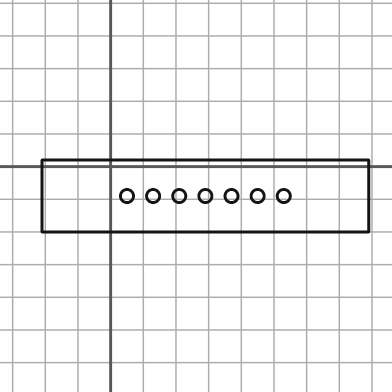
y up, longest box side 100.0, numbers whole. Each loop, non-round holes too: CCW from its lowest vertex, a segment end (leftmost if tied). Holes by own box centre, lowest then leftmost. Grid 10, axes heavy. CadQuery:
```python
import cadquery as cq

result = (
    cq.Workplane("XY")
    .moveTo(-21.0, -20.0)
    .lineTo(79.0, -20.0)
    .lineTo(79.0, 2.0)
    .lineTo(-21.0, 2.0)
    .close()
    .moveTo(5.0, -9.0)
    .circle(2.0)
    .moveTo(13.0, -9.0)
    .circle(2.0)
    .moveTo(21.0, -9.0)
    .circle(2.0)
    .moveTo(29.0, -9.0)
    .circle(2.0)
    .moveTo(37.0, -9.0)
    .circle(2.0)
    .moveTo(45.0, -9.0)
    .circle(2.0)
    .moveTo(53.0, -9.0)
    .circle(2.0)
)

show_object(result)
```